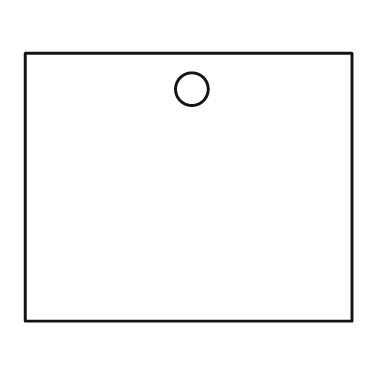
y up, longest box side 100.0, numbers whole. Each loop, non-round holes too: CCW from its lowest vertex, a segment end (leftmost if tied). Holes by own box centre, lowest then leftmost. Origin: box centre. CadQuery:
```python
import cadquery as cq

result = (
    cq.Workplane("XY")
    .moveTo(-50.0, -41.0)
    .lineTo(50.0, -41.0)
    .lineTo(50.0, 41.0)
    .lineTo(-50.0, 41.0)
    .close()
    .moveTo(1.0, 30.0)
    .circle(5.0)
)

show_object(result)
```